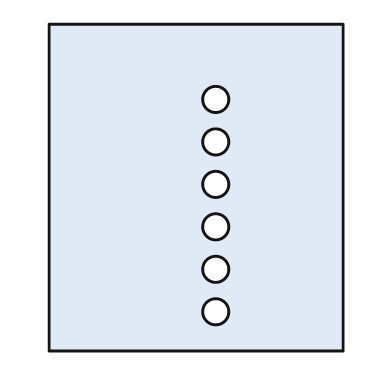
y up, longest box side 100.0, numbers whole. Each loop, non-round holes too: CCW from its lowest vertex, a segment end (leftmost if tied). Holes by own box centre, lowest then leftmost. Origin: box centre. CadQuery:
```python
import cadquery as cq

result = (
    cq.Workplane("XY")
    .moveTo(-45.0, -50.0)
    .lineTo(45.0, -50.0)
    .lineTo(45.0, 50.0)
    .lineTo(-45.0, 50.0)
    .close()
    .moveTo(6.0, -38.0)
    .circle(4.0)
    .moveTo(6.0, -25.0)
    .circle(4.0)
    .moveTo(6.0, -12.0)
    .circle(4.0)
    .moveTo(6.0, 1.0)
    .circle(4.0)
    .moveTo(6.0, 14.0)
    .circle(4.0)
    .moveTo(6.0, 27.0)
    .circle(4.0)
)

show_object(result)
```